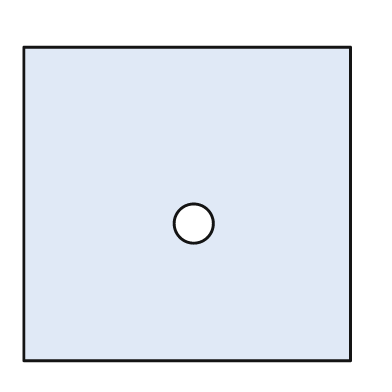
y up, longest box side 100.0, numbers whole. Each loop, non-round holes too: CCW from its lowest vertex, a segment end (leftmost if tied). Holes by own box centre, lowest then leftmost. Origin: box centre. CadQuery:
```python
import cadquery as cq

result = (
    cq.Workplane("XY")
    .moveTo(-50.0, -48.0)
    .lineTo(50.0, -48.0)
    .lineTo(50.0, 48.0)
    .lineTo(-50.0, 48.0)
    .close()
    .moveTo(2.0, -6.0)
    .circle(6.0)
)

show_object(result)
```